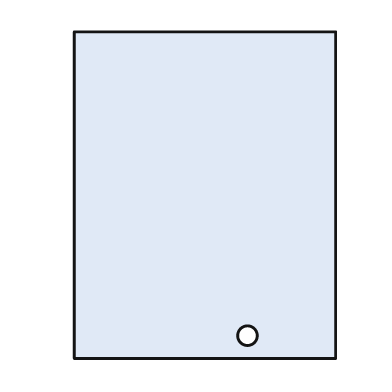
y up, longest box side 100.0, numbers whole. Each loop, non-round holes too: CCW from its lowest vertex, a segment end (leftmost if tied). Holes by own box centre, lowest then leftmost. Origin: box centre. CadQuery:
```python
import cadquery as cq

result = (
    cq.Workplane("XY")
    .moveTo(-40.0, -50.0)
    .lineTo(40.0, -50.0)
    .lineTo(40.0, 50.0)
    .lineTo(-40.0, 50.0)
    .close()
    .moveTo(13.0, -43.0)
    .circle(3.0)
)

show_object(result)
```